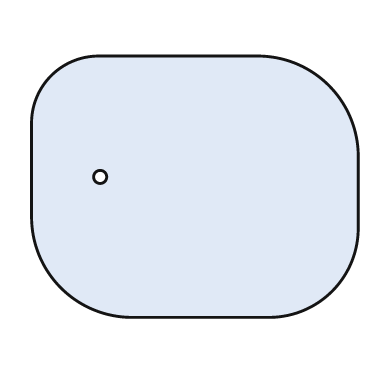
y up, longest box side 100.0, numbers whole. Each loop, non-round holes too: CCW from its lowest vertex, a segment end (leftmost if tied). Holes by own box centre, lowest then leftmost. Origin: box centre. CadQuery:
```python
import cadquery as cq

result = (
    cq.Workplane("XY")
    .moveTo(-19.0, -40.0)
    .lineTo(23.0, -40.0)
    .threePointArc((42.0, -32.0), (50.0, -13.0))
    .lineTo(50.0, 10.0)
    .threePointArc((41.0, 31.0), (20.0, 40.0))
    .lineTo(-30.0, 40.0)
    .threePointArc((-44.0, 34.0), (-50.0, 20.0))
    .lineTo(-50.0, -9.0)
    .threePointArc((-41.0, -31.0), (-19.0, -40.0))
    .close()
    .moveTo(-29.0, 3.0)
    .circle(2.0)
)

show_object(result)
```